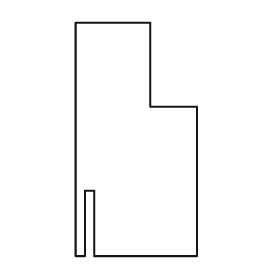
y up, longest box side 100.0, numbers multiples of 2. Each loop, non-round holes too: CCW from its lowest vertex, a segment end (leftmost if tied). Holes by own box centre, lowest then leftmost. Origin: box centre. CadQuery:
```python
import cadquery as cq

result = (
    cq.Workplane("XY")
    .moveTo(-26.0, -50.0)
    .lineTo(-22.0, -50.0)
    .lineTo(-22.0, -22.0)
    .lineTo(-18.0, -22.0)
    .lineTo(-18.0, -50.0)
    .lineTo(26.0, -50.0)
    .lineTo(26.0, 14.0)
    .lineTo(6.0, 14.0)
    .lineTo(6.0, 50.0)
    .lineTo(-26.0, 50.0)
    .close()
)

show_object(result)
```